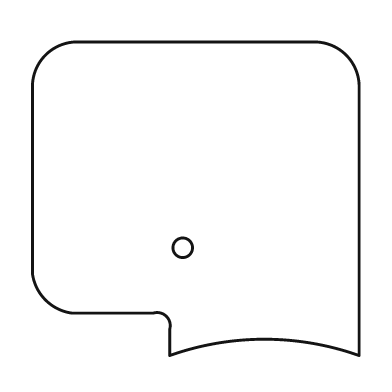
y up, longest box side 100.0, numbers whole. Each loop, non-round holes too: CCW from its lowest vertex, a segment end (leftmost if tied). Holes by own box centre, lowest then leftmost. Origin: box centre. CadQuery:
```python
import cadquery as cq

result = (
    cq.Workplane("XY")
    .moveTo(-8.0, -48.0)
    .threePointArc((21.0, -43.0), (50.0, -48.0))
    .lineTo(50.0, 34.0)
    .threePointArc((46.0, 44.0), (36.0, 48.0))
    .lineTo(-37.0, 48.0)
    .threePointArc((-46.0, 44.0), (-50.0, 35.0))
    .lineTo(-50.0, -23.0)
    .threePointArc((-46.0, -31.0), (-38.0, -35.0))
    .lineTo(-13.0, -35.0)
    .threePointArc((-9.0, -36.0), (-8.0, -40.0))
    .close()
    .moveTo(-4.0, -15.0)
    .circle(3.0)
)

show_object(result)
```